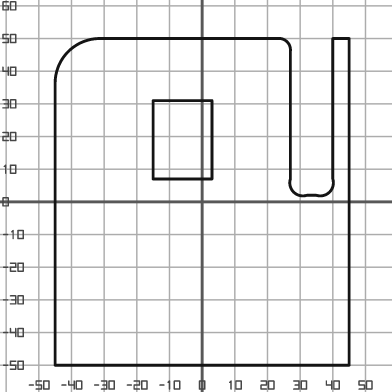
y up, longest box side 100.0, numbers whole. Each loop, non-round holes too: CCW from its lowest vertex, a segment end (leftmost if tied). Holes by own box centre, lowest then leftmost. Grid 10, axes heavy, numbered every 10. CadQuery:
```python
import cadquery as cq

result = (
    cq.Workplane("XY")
    .moveTo(-45.0, -50.0)
    .lineTo(45.0, -50.0)
    .lineTo(45.0, 50.0)
    .lineTo(40.0, 50.0)
    .lineTo(40.0, 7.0)
    .threePointArc((39.0, 3.0), (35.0, 2.0))
    .lineTo(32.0, 2.0)
    .threePointArc((28.0, 3.0), (27.0, 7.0))
    .lineTo(27.0, 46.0)
    .threePointArc((26.0, 49.0), (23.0, 50.0))
    .lineTo(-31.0, 50.0)
    .threePointArc((-41.0, 46.0), (-45.0, 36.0))
    .close()
    .moveTo(-15.0, 7.0)
    .lineTo(3.0, 7.0)
    .lineTo(3.0, 31.0)
    .lineTo(-15.0, 31.0)
    .close()
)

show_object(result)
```